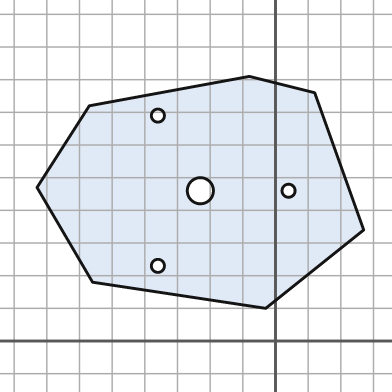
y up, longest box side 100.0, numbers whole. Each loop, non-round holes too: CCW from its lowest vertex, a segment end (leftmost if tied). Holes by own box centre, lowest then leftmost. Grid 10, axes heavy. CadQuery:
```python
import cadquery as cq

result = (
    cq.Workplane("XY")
    .moveTo(-3.0, 10.0)
    .lineTo(27.0, 34.0)
    .lineTo(12.0, 76.0)
    .lineTo(-8.0, 81.0)
    .lineTo(-57.0, 72.0)
    .lineTo(-73.0, 47.0)
    .lineTo(-56.0, 18.0)
    .close()
    .moveTo(-36.0, 23.0)
    .circle(2.0)
    .moveTo(-23.0, 46.0)
    .circle(4.0)
    .moveTo(4.0, 46.0)
    .circle(2.0)
    .moveTo(-36.0, 69.0)
    .circle(2.0)
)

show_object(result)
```